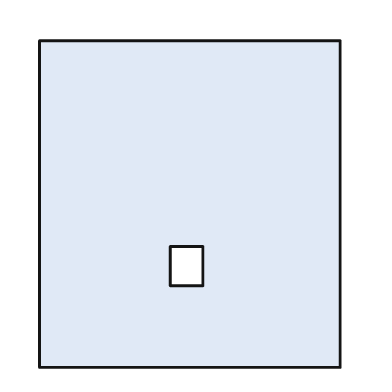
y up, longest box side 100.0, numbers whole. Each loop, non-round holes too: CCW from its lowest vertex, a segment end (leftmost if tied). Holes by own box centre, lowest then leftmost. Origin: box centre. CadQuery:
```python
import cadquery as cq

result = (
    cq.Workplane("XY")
    .moveTo(-46.0, -50.0)
    .lineTo(46.0, -50.0)
    .lineTo(46.0, 50.0)
    .lineTo(-46.0, 50.0)
    .close()
    .moveTo(-6.0, -25.0)
    .lineTo(4.0, -25.0)
    .lineTo(4.0, -13.0)
    .lineTo(-6.0, -13.0)
    .close()
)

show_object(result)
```